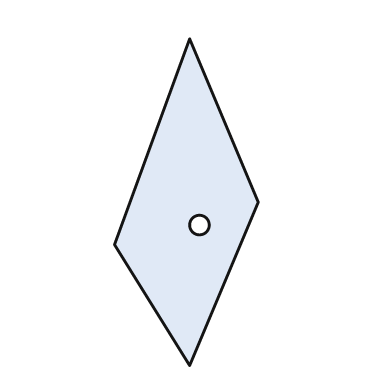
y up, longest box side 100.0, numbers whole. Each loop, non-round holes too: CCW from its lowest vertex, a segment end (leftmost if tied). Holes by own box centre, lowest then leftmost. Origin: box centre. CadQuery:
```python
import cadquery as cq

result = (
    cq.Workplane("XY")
    .moveTo(1.0, -50.0)
    .lineTo(22.0, 0.0)
    .lineTo(1.0, 50.0)
    .lineTo(-22.0, -13.0)
    .close()
    .moveTo(4.0, -7.0)
    .circle(3.0)
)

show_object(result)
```